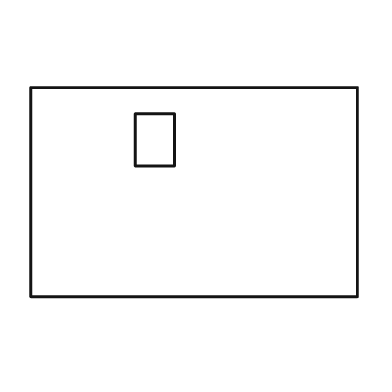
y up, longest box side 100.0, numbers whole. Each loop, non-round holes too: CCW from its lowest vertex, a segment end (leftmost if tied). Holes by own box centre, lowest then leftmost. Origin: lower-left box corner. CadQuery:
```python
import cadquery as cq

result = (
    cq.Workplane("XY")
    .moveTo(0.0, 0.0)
    .lineTo(100.0, 0.0)
    .lineTo(100.0, 64.0)
    .lineTo(0.0, 64.0)
    .close()
    .moveTo(32.0, 40.0)
    .lineTo(44.0, 40.0)
    .lineTo(44.0, 56.0)
    .lineTo(32.0, 56.0)
    .close()
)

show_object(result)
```